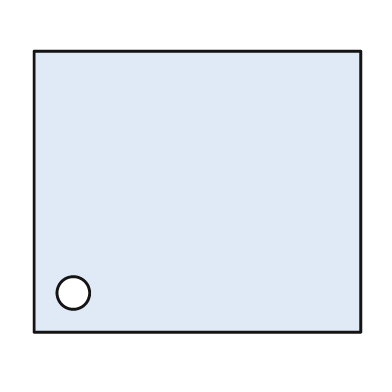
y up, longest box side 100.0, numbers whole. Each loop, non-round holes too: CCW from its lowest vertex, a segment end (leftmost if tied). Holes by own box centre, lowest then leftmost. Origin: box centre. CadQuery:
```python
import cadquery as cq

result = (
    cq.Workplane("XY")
    .moveTo(-50.0, -43.0)
    .lineTo(50.0, -43.0)
    .lineTo(50.0, 43.0)
    .lineTo(-50.0, 43.0)
    .close()
    .moveTo(-38.0, -31.0)
    .circle(5.0)
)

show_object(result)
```